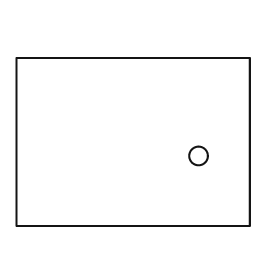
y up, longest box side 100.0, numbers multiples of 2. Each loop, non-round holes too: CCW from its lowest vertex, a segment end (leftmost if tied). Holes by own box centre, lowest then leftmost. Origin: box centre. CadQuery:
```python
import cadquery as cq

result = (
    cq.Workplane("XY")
    .moveTo(-50.0, -36.0)
    .lineTo(50.0, -36.0)
    .lineTo(50.0, 36.0)
    .lineTo(-50.0, 36.0)
    .close()
    .moveTo(28.0, -6.0)
    .circle(4.0)
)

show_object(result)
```